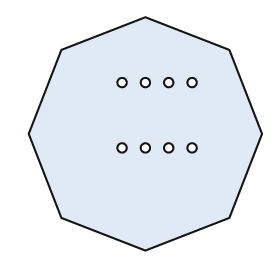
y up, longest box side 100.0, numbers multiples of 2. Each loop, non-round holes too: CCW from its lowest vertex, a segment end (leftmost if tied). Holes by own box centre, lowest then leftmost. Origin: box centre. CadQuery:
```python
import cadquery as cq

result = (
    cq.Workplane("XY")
    .moveTo(0.0, -50.0)
    .lineTo(36.0, -36.0)
    .lineTo(50.0, 0.0)
    .lineTo(36.0, 36.0)
    .lineTo(0.0, 50.0)
    .lineTo(-36.0, 36.0)
    .lineTo(-50.0, 0.0)
    .lineTo(-36.0, -36.0)
    .close()
    .moveTo(-10.0, -6.0)
    .circle(2.0)
    .moveTo(0.0, -6.0)
    .circle(2.0)
    .moveTo(10.0, -6.0)
    .circle(2.0)
    .moveTo(20.0, -6.0)
    .circle(2.0)
    .moveTo(-10.0, 22.0)
    .circle(2.0)
    .moveTo(0.0, 22.0)
    .circle(2.0)
    .moveTo(10.0, 22.0)
    .circle(2.0)
    .moveTo(20.0, 22.0)
    .circle(2.0)
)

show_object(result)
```